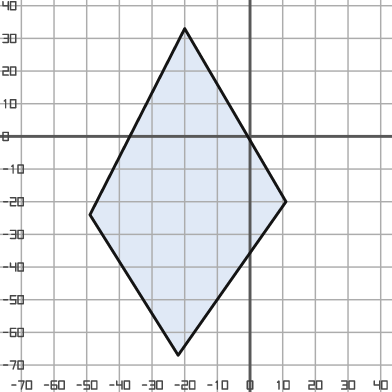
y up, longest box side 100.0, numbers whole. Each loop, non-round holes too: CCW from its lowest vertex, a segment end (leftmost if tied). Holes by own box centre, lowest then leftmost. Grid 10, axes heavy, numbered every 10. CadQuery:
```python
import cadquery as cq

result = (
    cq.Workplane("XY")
    .moveTo(-22.0, -67.0)
    .lineTo(11.0, -20.0)
    .lineTo(-20.0, 33.0)
    .lineTo(-49.0, -24.0)
    .close()
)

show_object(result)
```